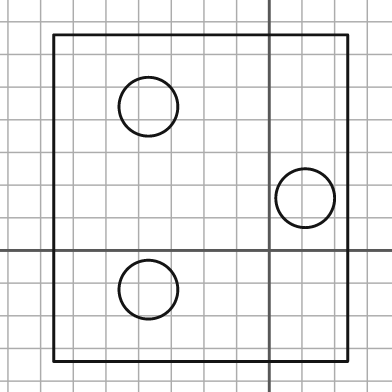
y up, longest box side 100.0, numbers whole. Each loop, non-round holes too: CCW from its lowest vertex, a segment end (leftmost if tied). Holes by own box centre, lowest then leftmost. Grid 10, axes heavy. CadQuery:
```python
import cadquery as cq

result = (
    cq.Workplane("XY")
    .moveTo(-66.0, -34.0)
    .lineTo(24.0, -34.0)
    .lineTo(24.0, 66.0)
    .lineTo(-66.0, 66.0)
    .close()
    .moveTo(-37.0, -12.0)
    .circle(9.0)
    .moveTo(11.0, 16.0)
    .circle(9.0)
    .moveTo(-37.0, 44.0)
    .circle(9.0)
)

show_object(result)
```